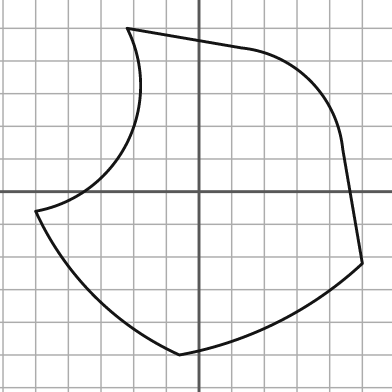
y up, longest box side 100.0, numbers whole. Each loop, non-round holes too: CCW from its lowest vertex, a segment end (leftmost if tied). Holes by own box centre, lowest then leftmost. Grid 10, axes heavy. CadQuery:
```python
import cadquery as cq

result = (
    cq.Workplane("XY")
    .moveTo(-6.0, -50.0)
    .threePointArc((24.0, -40.0), (50.0, -22.0))
    .lineTo(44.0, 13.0)
    .threePointArc((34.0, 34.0), (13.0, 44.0))
    .lineTo(-22.0, 50.0)
    .threePointArc((-22.0, 15.0), (-50.0, -6.0))
    .threePointArc((-32.0, -32.0), (-6.0, -50.0))
    .close()
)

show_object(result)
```